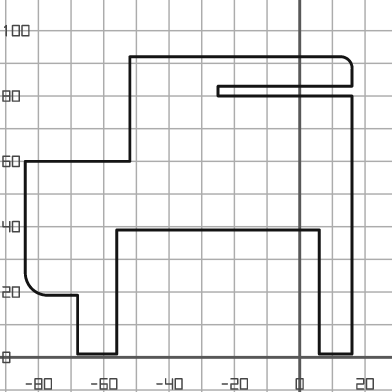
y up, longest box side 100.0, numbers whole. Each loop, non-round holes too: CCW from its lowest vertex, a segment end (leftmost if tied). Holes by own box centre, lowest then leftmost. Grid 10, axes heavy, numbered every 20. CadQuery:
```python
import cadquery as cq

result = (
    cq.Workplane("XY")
    .moveTo(-68.0, 1.0)
    .lineTo(-56.0, 1.0)
    .lineTo(-56.0, 39.0)
    .lineTo(6.0, 39.0)
    .lineTo(6.0, 1.0)
    .lineTo(16.0, 1.0)
    .lineTo(16.0, 80.0)
    .lineTo(-25.0, 80.0)
    .lineTo(-25.0, 83.0)
    .lineTo(16.0, 83.0)
    .lineTo(16.0, 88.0)
    .threePointArc((15.0, 91.0), (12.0, 92.0))
    .lineTo(-52.0, 92.0)
    .lineTo(-52.0, 60.0)
    .lineTo(-84.0, 60.0)
    .lineTo(-84.0, 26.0)
    .threePointArc((-82.0, 21.0), (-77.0, 19.0))
    .lineTo(-68.0, 19.0)
    .close()
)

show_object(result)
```